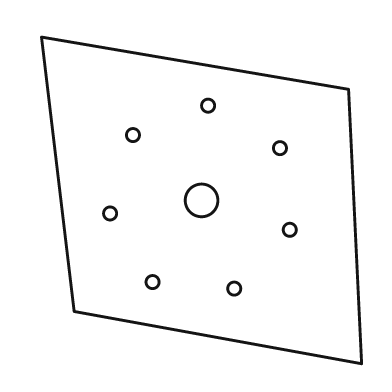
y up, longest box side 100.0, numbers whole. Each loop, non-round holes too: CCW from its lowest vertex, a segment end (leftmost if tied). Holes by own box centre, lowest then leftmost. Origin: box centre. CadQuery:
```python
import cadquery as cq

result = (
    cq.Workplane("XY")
    .moveTo(49.0, -50.0)
    .lineTo(45.0, 34.0)
    .lineTo(-49.0, 50.0)
    .lineTo(-39.0, -34.0)
    .close()
    .moveTo(10.0, -27.0)
    .circle(2.0)
    .moveTo(-15.0, -25.0)
    .circle(2.0)
    .moveTo(27.0, -9.0)
    .circle(2.0)
    .moveTo(-28.0, -4.0)
    .circle(2.0)
    .moveTo(0.0, 0.0)
    .circle(5.0)
    .moveTo(24.0, 16.0)
    .circle(2.0)
    .moveTo(-21.0, 20.0)
    .circle(2.0)
    .moveTo(2.0, 29.0)
    .circle(2.0)
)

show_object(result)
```